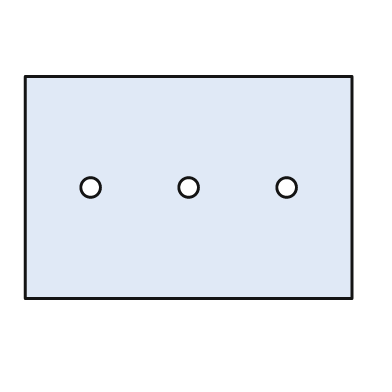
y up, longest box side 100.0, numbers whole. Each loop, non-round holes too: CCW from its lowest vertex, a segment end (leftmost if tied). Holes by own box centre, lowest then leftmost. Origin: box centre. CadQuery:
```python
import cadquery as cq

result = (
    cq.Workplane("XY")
    .moveTo(-50.0, -34.0)
    .lineTo(50.0, -34.0)
    .lineTo(50.0, 34.0)
    .lineTo(-50.0, 34.0)
    .close()
    .moveTo(-30.0, 0.0)
    .circle(3.0)
    .moveTo(0.0, 0.0)
    .circle(3.0)
    .moveTo(30.0, 0.0)
    .circle(3.0)
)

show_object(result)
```